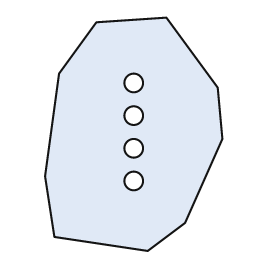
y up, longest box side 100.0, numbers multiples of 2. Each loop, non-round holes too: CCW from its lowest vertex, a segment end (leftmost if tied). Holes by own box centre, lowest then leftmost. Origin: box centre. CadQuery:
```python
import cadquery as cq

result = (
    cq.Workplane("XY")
    .moveTo(6.0, -50.0)
    .lineTo(22.0, -38.0)
    .lineTo(38.0, -2.0)
    .lineTo(36.0, 20.0)
    .lineTo(14.0, 50.0)
    .lineTo(-16.0, 48.0)
    .lineTo(-32.0, 26.0)
    .lineTo(-38.0, -18.0)
    .lineTo(-34.0, -44.0)
    .close()
    .moveTo(0.0, -20.0)
    .circle(4.0)
    .moveTo(0.0, -6.0)
    .circle(4.0)
    .moveTo(0.0, 8.0)
    .circle(4.0)
    .moveTo(0.0, 22.0)
    .circle(4.0)
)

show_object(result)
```